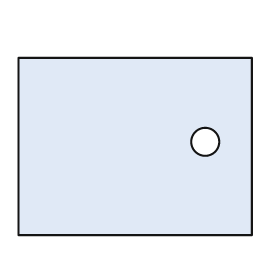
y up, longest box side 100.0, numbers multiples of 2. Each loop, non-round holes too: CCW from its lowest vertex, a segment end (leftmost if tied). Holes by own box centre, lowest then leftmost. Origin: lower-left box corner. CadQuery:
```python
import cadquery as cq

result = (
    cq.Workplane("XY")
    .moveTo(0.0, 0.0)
    .lineTo(100.0, 0.0)
    .lineTo(100.0, 76.0)
    .lineTo(0.0, 76.0)
    .close()
    .moveTo(80.0, 40.0)
    .circle(6.0)
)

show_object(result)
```